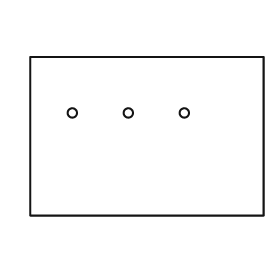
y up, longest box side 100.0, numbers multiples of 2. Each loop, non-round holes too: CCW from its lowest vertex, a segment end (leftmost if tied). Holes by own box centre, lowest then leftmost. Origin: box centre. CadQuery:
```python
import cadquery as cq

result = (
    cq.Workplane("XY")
    .moveTo(-50.0, -34.0)
    .lineTo(50.0, -34.0)
    .lineTo(50.0, 34.0)
    .lineTo(-50.0, 34.0)
    .close()
    .moveTo(-32.0, 10.0)
    .circle(2.0)
    .moveTo(-8.0, 10.0)
    .circle(2.0)
    .moveTo(16.0, 10.0)
    .circle(2.0)
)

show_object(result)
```